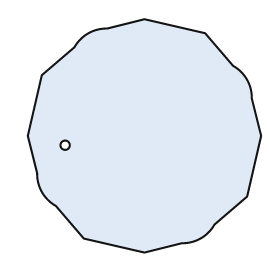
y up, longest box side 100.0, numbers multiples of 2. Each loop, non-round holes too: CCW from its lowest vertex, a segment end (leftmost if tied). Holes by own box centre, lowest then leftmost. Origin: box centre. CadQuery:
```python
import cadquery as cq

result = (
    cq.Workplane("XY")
    .moveTo(0.0, -50.0)
    .lineTo(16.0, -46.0)
    .threePointArc((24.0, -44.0), (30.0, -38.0))
    .lineTo(44.0, -26.0)
    .lineTo(50.0, 0.0)
    .lineTo(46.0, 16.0)
    .threePointArc((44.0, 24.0), (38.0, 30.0))
    .lineTo(26.0, 44.0)
    .lineTo(0.0, 50.0)
    .lineTo(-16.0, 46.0)
    .threePointArc((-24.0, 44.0), (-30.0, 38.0))
    .lineTo(-44.0, 26.0)
    .lineTo(-50.0, 0.0)
    .lineTo(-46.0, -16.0)
    .threePointArc((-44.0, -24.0), (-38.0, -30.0))
    .lineTo(-26.0, -44.0)
    .close()
    .moveTo(-34.0, -4.0)
    .circle(2.0)
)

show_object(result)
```